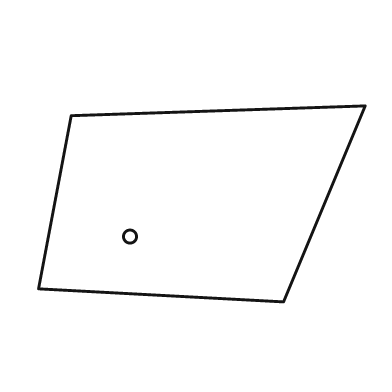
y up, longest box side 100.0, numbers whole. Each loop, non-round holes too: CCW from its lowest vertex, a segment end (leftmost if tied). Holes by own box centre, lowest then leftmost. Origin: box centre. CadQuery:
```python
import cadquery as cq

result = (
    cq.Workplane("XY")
    .moveTo(25.0, -30.0)
    .lineTo(50.0, 30.0)
    .lineTo(-40.0, 27.0)
    .lineTo(-50.0, -26.0)
    .close()
    .moveTo(-22.0, -10.0)
    .circle(2.0)
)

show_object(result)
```